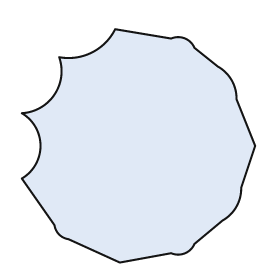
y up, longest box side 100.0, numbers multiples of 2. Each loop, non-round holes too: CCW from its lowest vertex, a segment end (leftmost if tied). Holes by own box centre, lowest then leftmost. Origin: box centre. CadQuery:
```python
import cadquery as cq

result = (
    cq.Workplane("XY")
    .moveTo(-8.0, -50.0)
    .lineTo(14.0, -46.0)
    .threePointArc((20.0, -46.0), (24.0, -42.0))
    .lineTo(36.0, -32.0)
    .threePointArc((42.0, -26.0), (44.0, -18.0))
    .lineTo(50.0, 0.0)
    .lineTo(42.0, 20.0)
    .threePointArc((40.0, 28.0), (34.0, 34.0))
    .lineTo(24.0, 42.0)
    .threePointArc((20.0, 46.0), (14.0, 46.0))
    .lineTo(-10.0, 50.0)
    .threePointArc((-20.0, 40.0), (-34.0, 38.0))
    .threePointArc((-36.0, 22.0), (-50.0, 14.0))
    .threePointArc((-42.0, 0.0), (-50.0, -14.0))
    .lineTo(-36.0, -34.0)
    .threePointArc((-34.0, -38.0), (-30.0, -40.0))
    .close()
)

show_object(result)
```